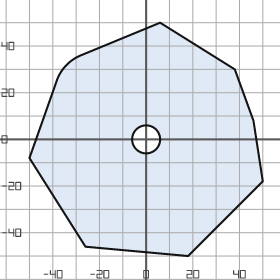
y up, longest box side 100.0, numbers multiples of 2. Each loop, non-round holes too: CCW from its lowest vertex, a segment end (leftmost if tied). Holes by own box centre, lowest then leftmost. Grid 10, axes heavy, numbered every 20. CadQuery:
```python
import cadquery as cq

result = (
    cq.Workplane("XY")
    .moveTo(18.0, -50.0)
    .lineTo(50.0, -18.0)
    .lineTo(46.0, 8.0)
    .lineTo(38.0, 30.0)
    .lineTo(6.0, 50.0)
    .lineTo(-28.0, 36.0)
    .threePointArc((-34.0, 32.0), (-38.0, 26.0))
    .lineTo(-50.0, -8.0)
    .lineTo(-26.0, -46.0)
    .close()
    .moveTo(0.0, 0.0)
    .circle(6.0)
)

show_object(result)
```